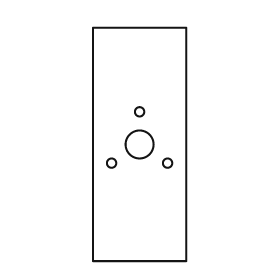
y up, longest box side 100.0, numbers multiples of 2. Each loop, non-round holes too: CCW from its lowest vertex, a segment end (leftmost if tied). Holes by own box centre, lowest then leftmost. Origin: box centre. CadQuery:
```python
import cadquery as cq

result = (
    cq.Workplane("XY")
    .moveTo(-20.0, -50.0)
    .lineTo(20.0, -50.0)
    .lineTo(20.0, 50.0)
    .lineTo(-20.0, 50.0)
    .close()
    .moveTo(-12.0, -8.0)
    .circle(2.0)
    .moveTo(12.0, -8.0)
    .circle(2.0)
    .moveTo(0.0, 0.0)
    .circle(6.0)
    .moveTo(0.0, 14.0)
    .circle(2.0)
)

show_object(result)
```